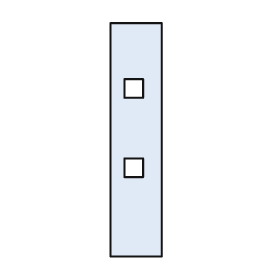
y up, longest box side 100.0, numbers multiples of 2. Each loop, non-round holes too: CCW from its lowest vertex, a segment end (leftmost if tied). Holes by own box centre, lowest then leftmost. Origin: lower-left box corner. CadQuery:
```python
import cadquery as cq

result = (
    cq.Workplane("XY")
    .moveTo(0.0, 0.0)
    .lineTo(22.0, 0.0)
    .lineTo(22.0, 100.0)
    .lineTo(0.0, 100.0)
    .close()
    .moveTo(6.0, 34.0)
    .lineTo(14.0, 34.0)
    .lineTo(14.0, 42.0)
    .lineTo(6.0, 42.0)
    .close()
    .moveTo(6.0, 68.0)
    .lineTo(14.0, 68.0)
    .lineTo(14.0, 76.0)
    .lineTo(6.0, 76.0)
    .close()
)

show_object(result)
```